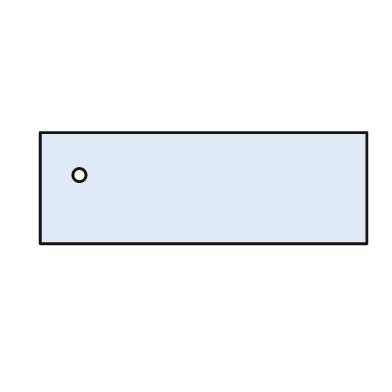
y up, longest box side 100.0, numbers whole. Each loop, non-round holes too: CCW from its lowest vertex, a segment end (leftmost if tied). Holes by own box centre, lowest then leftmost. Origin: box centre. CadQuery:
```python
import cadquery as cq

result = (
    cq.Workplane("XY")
    .moveTo(-50.0, -17.0)
    .lineTo(50.0, -17.0)
    .lineTo(50.0, 17.0)
    .lineTo(-50.0, 17.0)
    .close()
    .moveTo(-38.0, 4.0)
    .circle(2.0)
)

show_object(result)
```